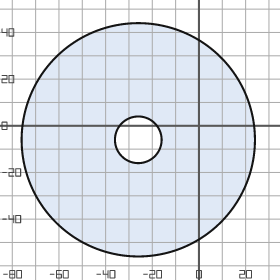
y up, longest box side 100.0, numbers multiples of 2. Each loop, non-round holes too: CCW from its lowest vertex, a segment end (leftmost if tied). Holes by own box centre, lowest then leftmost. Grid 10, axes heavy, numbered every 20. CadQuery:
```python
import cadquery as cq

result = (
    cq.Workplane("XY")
    .moveTo(-26.0, -6.0)
    .circle(50.0)
    .moveTo(-26.0, -6.0)
    .circle(10.0)
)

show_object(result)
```